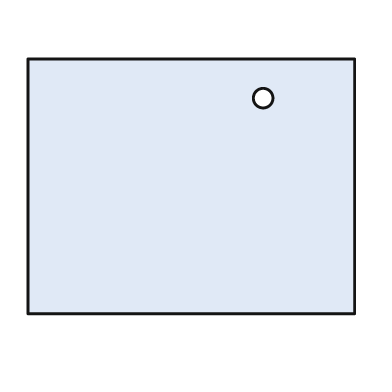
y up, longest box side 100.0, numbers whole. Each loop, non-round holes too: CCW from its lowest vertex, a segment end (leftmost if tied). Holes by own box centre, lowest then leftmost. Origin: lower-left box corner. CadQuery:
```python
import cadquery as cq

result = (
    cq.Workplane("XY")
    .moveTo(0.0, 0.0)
    .lineTo(100.0, 0.0)
    .lineTo(100.0, 78.0)
    .lineTo(0.0, 78.0)
    .close()
    .moveTo(72.0, 66.0)
    .circle(3.0)
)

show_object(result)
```